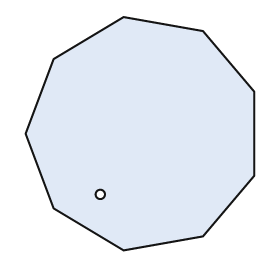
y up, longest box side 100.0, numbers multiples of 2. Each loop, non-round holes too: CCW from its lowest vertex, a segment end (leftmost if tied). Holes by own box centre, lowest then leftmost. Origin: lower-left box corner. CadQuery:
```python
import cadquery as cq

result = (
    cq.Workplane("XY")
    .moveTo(42.0, 0.0)
    .lineTo(76.0, 6.0)
    .lineTo(98.0, 32.0)
    .lineTo(98.0, 68.0)
    .lineTo(76.0, 94.0)
    .lineTo(42.0, 100.0)
    .lineTo(12.0, 82.0)
    .lineTo(0.0, 50.0)
    .lineTo(12.0, 18.0)
    .close()
    .moveTo(32.0, 24.0)
    .circle(2.0)
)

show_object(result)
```